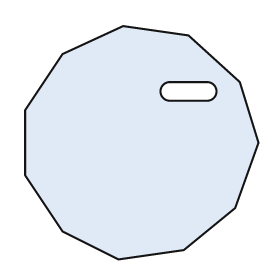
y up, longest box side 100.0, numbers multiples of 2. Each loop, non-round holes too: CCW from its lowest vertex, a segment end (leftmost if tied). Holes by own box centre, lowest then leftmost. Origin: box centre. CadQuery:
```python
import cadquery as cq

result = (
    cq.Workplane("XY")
    .moveTo(-10.0, -50.0)
    .lineTo(18.0, -46.0)
    .lineTo(40.0, -28.0)
    .lineTo(50.0, 0.0)
    .lineTo(42.0, 26.0)
    .lineTo(20.0, 46.0)
    .lineTo(-8.0, 50.0)
    .lineTo(-34.0, 38.0)
    .lineTo(-50.0, 14.0)
    .lineTo(-50.0, -14.0)
    .lineTo(-34.0, -38.0)
    .close()
    .moveTo(12.0, 18.0)
    .lineTo(28.0, 18.0)
    .threePointArc((32.0, 22.0), (28.0, 26.0))
    .lineTo(12.0, 26.0)
    .threePointArc((8.0, 22.0), (12.0, 18.0))
    .close()
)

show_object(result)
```